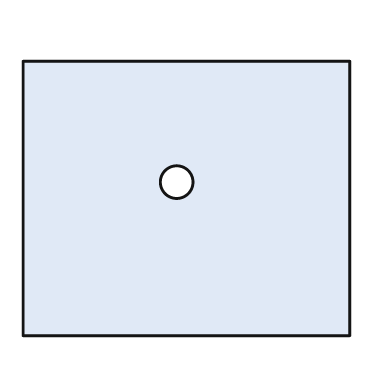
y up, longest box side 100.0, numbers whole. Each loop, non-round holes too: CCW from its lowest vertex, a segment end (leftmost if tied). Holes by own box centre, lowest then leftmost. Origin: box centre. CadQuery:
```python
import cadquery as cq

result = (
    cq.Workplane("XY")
    .moveTo(-50.0, -42.0)
    .lineTo(50.0, -42.0)
    .lineTo(50.0, 42.0)
    .lineTo(-50.0, 42.0)
    .close()
    .moveTo(-3.0, 5.0)
    .circle(5.0)
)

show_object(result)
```